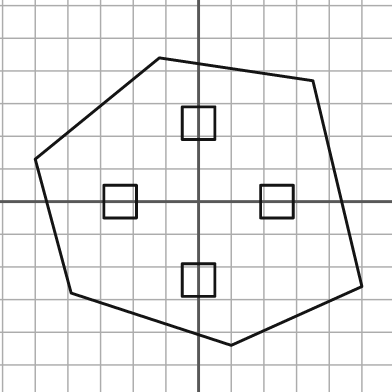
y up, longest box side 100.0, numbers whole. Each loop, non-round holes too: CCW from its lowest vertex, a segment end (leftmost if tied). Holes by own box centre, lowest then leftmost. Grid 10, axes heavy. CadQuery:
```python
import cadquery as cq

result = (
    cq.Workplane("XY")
    .moveTo(10.0, -44.0)
    .lineTo(50.0, -26.0)
    .lineTo(35.0, 37.0)
    .lineTo(-12.0, 44.0)
    .lineTo(-50.0, 13.0)
    .lineTo(-39.0, -28.0)
    .close()
    .moveTo(-5.0, -29.0)
    .lineTo(5.0, -29.0)
    .lineTo(5.0, -19.0)
    .lineTo(-5.0, -19.0)
    .close()
    .moveTo(-29.0, -5.0)
    .lineTo(-19.0, -5.0)
    .lineTo(-19.0, 5.0)
    .lineTo(-29.0, 5.0)
    .close()
    .moveTo(19.0, -5.0)
    .lineTo(29.0, -5.0)
    .lineTo(29.0, 5.0)
    .lineTo(19.0, 5.0)
    .close()
    .moveTo(-5.0, 19.0)
    .lineTo(5.0, 19.0)
    .lineTo(5.0, 29.0)
    .lineTo(-5.0, 29.0)
    .close()
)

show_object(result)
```